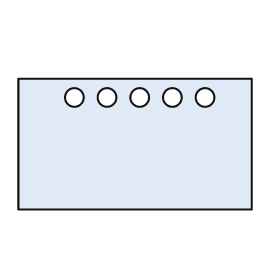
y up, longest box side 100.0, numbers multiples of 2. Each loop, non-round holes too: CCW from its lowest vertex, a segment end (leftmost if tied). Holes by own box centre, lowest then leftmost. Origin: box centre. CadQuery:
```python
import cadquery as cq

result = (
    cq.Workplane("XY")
    .moveTo(-50.0, -28.0)
    .lineTo(50.0, -28.0)
    .lineTo(50.0, 28.0)
    .lineTo(-50.0, 28.0)
    .close()
    .moveTo(-26.0, 20.0)
    .circle(4.0)
    .moveTo(-12.0, 20.0)
    .circle(4.0)
    .moveTo(2.0, 20.0)
    .circle(4.0)
    .moveTo(16.0, 20.0)
    .circle(4.0)
    .moveTo(30.0, 20.0)
    .circle(4.0)
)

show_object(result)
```